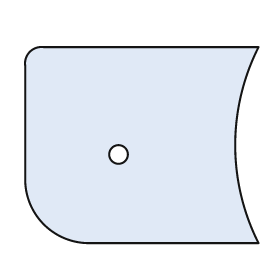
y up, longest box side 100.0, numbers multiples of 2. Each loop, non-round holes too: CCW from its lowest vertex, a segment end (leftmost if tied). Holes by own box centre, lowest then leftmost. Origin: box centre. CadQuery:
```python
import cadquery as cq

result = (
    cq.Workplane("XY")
    .moveTo(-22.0, -42.0)
    .lineTo(50.0, -42.0)
    .threePointArc((40.0, 0.0), (50.0, 42.0))
    .lineTo(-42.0, 42.0)
    .threePointArc((-48.0, 40.0), (-50.0, 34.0))
    .lineTo(-50.0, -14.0)
    .threePointArc((-42.0, -34.0), (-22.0, -42.0))
    .close()
    .moveTo(-10.0, -4.0)
    .circle(4.0)
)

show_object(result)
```